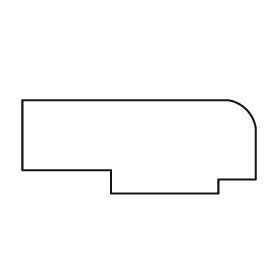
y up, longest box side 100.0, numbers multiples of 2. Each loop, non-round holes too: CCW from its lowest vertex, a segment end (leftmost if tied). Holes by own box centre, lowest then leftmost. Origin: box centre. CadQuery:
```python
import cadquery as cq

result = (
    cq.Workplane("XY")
    .moveTo(-12.0, -20.0)
    .lineTo(34.0, -20.0)
    .lineTo(34.0, -14.0)
    .lineTo(50.0, -14.0)
    .lineTo(50.0, 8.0)
    .threePointArc((46.0, 16.0), (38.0, 20.0))
    .lineTo(-50.0, 20.0)
    .lineTo(-50.0, -10.0)
    .lineTo(-12.0, -10.0)
    .close()
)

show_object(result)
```